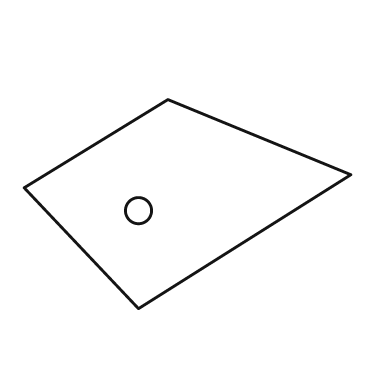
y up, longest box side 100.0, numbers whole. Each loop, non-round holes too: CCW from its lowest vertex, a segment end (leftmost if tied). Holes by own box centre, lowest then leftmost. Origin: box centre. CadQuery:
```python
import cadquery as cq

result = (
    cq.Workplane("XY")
    .moveTo(-15.0, -32.0)
    .lineTo(50.0, 9.0)
    .lineTo(-6.0, 32.0)
    .lineTo(-50.0, 5.0)
    .close()
    .moveTo(-15.0, -2.0)
    .circle(4.0)
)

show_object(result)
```